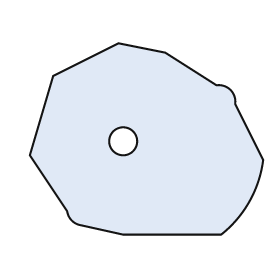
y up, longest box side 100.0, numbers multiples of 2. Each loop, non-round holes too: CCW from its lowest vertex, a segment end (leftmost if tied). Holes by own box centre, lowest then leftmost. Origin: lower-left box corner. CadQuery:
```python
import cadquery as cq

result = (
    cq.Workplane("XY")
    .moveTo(40.0, 0.0)
    .lineTo(82.0, 0.0)
    .threePointArc((94.0, 14.0), (100.0, 32.0))
    .lineTo(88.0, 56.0)
    .threePointArc((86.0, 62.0), (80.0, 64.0))
    .lineTo(58.0, 78.0)
    .lineTo(38.0, 82.0)
    .lineTo(10.0, 68.0)
    .lineTo(0.0, 34.0)
    .lineTo(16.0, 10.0)
    .threePointArc((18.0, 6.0), (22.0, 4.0))
    .close()
    .moveTo(40.0, 40.0)
    .circle(6.0)
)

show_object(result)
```